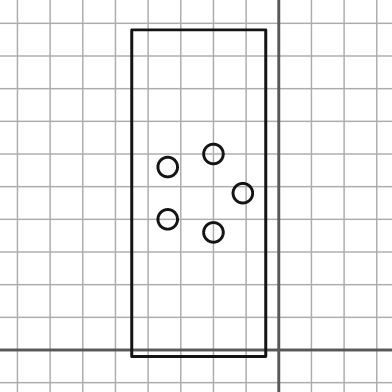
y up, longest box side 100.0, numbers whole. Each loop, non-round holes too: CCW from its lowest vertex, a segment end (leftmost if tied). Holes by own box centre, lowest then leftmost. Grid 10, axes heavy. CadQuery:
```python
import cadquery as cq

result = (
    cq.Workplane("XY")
    .moveTo(-45.0, -2.0)
    .lineTo(-4.0, -2.0)
    .lineTo(-4.0, 98.0)
    .lineTo(-45.0, 98.0)
    .close()
    .moveTo(-20.0, 36.0)
    .circle(3.0)
    .moveTo(-34.0, 40.0)
    .circle(3.0)
    .moveTo(-11.0, 48.0)
    .circle(3.0)
    .moveTo(-34.0, 56.0)
    .circle(3.0)
    .moveTo(-20.0, 60.0)
    .circle(3.0)
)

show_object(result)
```